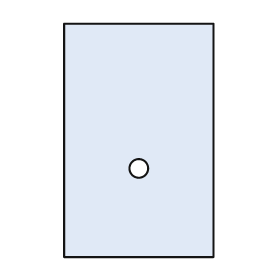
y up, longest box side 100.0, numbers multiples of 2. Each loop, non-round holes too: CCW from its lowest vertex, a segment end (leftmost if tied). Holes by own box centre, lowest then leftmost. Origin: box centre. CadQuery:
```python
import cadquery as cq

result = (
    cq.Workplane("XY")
    .moveTo(-32.0, -50.0)
    .lineTo(32.0, -50.0)
    .lineTo(32.0, 50.0)
    .lineTo(-32.0, 50.0)
    .close()
    .moveTo(0.0, -12.0)
    .circle(4.0)
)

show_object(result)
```